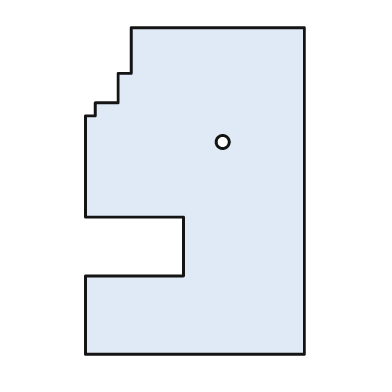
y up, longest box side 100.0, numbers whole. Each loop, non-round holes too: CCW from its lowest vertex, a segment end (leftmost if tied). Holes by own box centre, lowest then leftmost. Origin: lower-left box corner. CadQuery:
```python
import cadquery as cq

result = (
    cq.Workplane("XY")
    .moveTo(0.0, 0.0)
    .lineTo(67.0, 0.0)
    .lineTo(67.0, 100.0)
    .lineTo(14.0, 100.0)
    .lineTo(14.0, 86.0)
    .lineTo(10.0, 86.0)
    .lineTo(10.0, 77.0)
    .lineTo(3.0, 77.0)
    .lineTo(3.0, 73.0)
    .lineTo(0.0, 73.0)
    .lineTo(0.0, 42.0)
    .lineTo(30.0, 42.0)
    .lineTo(30.0, 24.0)
    .lineTo(0.0, 24.0)
    .close()
    .moveTo(42.0, 65.0)
    .circle(2.0)
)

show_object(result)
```